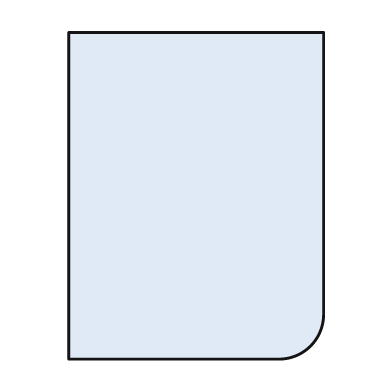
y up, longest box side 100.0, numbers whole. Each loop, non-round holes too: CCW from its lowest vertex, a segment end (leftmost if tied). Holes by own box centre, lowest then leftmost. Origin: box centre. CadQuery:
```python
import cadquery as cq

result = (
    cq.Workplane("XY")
    .moveTo(-39.0, -50.0)
    .lineTo(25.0, -50.0)
    .threePointArc((35.0, -46.0), (39.0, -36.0))
    .lineTo(39.0, 50.0)
    .lineTo(-39.0, 50.0)
    .close()
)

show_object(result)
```